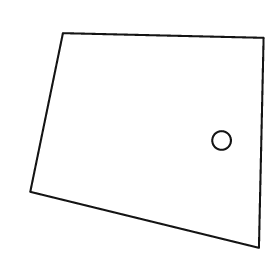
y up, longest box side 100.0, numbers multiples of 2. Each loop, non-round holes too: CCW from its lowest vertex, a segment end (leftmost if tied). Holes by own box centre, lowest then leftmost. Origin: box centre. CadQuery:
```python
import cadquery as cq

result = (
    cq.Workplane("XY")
    .moveTo(48.0, -46.0)
    .lineTo(50.0, 44.0)
    .lineTo(-36.0, 46.0)
    .lineTo(-50.0, -22.0)
    .close()
    .moveTo(32.0, 0.0)
    .circle(4.0)
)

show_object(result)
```